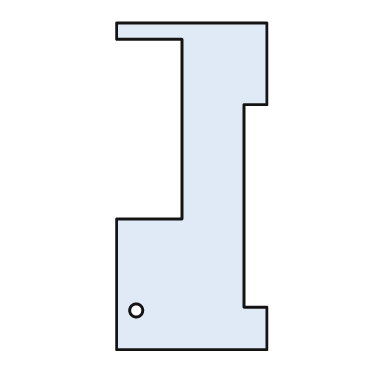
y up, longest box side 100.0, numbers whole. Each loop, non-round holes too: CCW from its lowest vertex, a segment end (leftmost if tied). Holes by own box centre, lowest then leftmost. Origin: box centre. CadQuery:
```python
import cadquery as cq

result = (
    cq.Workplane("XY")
    .moveTo(-23.0, -50.0)
    .lineTo(23.0, -50.0)
    .lineTo(23.0, -37.0)
    .lineTo(16.0, -37.0)
    .lineTo(16.0, 25.0)
    .lineTo(23.0, 25.0)
    .lineTo(23.0, 50.0)
    .lineTo(-23.0, 50.0)
    .lineTo(-23.0, 45.0)
    .lineTo(-3.0, 45.0)
    .lineTo(-3.0, -10.0)
    .lineTo(-23.0, -10.0)
    .close()
    .moveTo(-17.0, -38.0)
    .circle(2.0)
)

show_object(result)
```